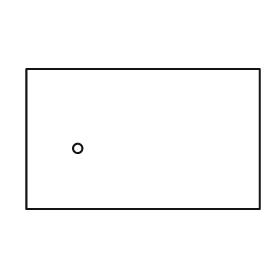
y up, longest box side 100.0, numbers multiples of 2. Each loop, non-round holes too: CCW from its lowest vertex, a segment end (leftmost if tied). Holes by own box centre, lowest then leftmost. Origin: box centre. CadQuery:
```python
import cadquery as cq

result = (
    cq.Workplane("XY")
    .moveTo(-50.0, -30.0)
    .lineTo(50.0, -30.0)
    .lineTo(50.0, 30.0)
    .lineTo(-50.0, 30.0)
    .close()
    .moveTo(-28.0, -4.0)
    .circle(2.0)
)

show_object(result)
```